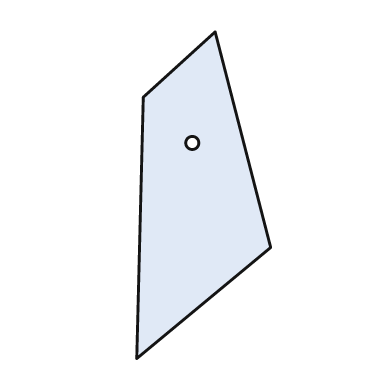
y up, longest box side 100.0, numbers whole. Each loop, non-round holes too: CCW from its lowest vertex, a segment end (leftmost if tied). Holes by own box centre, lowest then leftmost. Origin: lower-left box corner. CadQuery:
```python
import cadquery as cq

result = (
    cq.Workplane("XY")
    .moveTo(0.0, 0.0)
    .lineTo(41.0, 34.0)
    .lineTo(24.0, 100.0)
    .lineTo(2.0, 80.0)
    .close()
    .moveTo(17.0, 66.0)
    .circle(2.0)
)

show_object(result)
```